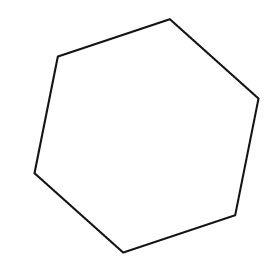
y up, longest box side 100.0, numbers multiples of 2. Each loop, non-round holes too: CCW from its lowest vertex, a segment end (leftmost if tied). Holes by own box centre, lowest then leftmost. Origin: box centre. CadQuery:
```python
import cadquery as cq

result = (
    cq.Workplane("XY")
    .moveTo(-10.0, -50.0)
    .lineTo(38.0, -34.0)
    .lineTo(48.0, 16.0)
    .lineTo(10.0, 50.0)
    .lineTo(-38.0, 34.0)
    .lineTo(-48.0, -16.0)
    .close()
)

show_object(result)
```